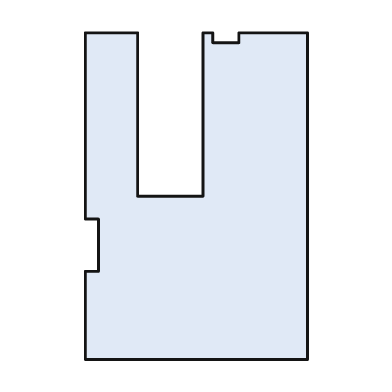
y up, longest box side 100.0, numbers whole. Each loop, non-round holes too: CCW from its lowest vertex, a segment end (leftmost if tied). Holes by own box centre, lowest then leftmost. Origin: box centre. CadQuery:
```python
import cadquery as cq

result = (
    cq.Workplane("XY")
    .moveTo(-34.0, -50.0)
    .lineTo(34.0, -50.0)
    .lineTo(34.0, 50.0)
    .lineTo(13.0, 50.0)
    .lineTo(13.0, 47.0)
    .lineTo(5.0, 47.0)
    .lineTo(5.0, 50.0)
    .lineTo(2.0, 50.0)
    .lineTo(2.0, 0.0)
    .lineTo(-18.0, 0.0)
    .lineTo(-18.0, 50.0)
    .lineTo(-34.0, 50.0)
    .lineTo(-34.0, -7.0)
    .lineTo(-30.0, -7.0)
    .lineTo(-30.0, -23.0)
    .lineTo(-34.0, -23.0)
    .close()
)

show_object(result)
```